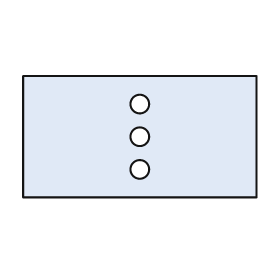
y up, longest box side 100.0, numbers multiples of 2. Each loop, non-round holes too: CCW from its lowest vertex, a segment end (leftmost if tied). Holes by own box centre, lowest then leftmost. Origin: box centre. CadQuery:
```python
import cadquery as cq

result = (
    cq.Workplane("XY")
    .moveTo(-50.0, -26.0)
    .lineTo(50.0, -26.0)
    .lineTo(50.0, 26.0)
    .lineTo(-50.0, 26.0)
    .close()
    .moveTo(0.0, -14.0)
    .circle(4.0)
    .moveTo(0.0, 0.0)
    .circle(4.0)
    .moveTo(0.0, 14.0)
    .circle(4.0)
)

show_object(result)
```